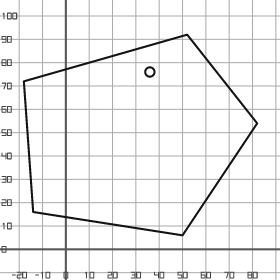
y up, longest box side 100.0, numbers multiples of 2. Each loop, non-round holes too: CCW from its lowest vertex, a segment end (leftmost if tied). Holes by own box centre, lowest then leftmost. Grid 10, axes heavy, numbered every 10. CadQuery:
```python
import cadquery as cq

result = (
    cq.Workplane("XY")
    .moveTo(50.0, 6.0)
    .lineTo(82.0, 54.0)
    .lineTo(52.0, 92.0)
    .lineTo(-18.0, 72.0)
    .lineTo(-14.0, 16.0)
    .close()
    .moveTo(36.0, 76.0)
    .circle(2.0)
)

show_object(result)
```